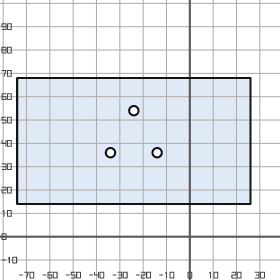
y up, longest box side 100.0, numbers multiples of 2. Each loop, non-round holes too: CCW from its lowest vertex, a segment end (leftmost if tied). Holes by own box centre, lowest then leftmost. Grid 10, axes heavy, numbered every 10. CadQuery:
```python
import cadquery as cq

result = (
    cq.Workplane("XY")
    .moveTo(-74.0, 14.0)
    .lineTo(26.0, 14.0)
    .lineTo(26.0, 68.0)
    .lineTo(-74.0, 68.0)
    .close()
    .moveTo(-34.0, 36.0)
    .circle(2.0)
    .moveTo(-14.0, 36.0)
    .circle(2.0)
    .moveTo(-24.0, 54.0)
    .circle(2.0)
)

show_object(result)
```